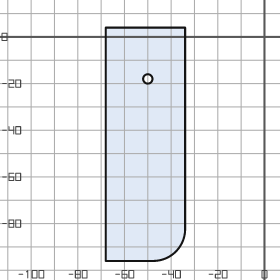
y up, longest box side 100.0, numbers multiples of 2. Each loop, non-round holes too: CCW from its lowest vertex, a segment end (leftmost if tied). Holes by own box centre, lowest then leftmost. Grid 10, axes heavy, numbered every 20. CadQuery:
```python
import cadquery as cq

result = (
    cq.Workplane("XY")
    .moveTo(-68.0, -96.0)
    .lineTo(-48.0, -96.0)
    .threePointArc((-38.0, -92.0), (-34.0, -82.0))
    .lineTo(-34.0, 4.0)
    .lineTo(-68.0, 4.0)
    .close()
    .moveTo(-50.0, -18.0)
    .circle(2.0)
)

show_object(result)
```